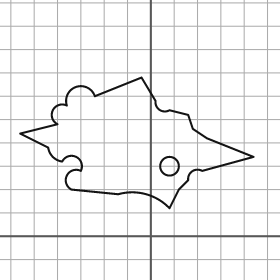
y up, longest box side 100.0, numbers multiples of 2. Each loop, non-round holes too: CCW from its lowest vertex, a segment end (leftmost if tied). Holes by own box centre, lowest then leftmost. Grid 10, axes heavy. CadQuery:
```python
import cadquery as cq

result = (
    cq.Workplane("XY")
    .moveTo(8.0, 12.0)
    .lineTo(12.0, 20.0)
    .lineTo(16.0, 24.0)
    .threePointArc((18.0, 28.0), (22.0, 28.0))
    .lineTo(44.0, 34.0)
    .lineTo(24.0, 42.0)
    .lineTo(18.0, 46.0)
    .lineTo(16.0, 52.0)
    .lineTo(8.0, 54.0)
    .threePointArc((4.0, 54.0), (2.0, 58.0))
    .lineTo(-4.0, 68.0)
    .lineTo(-24.0, 60.0)
    .threePointArc((-32.0, 64.0), (-36.0, 56.0))
    .threePointArc((-42.0, 54.0), (-40.0, 48.0))
    .lineTo(-56.0, 44.0)
    .lineTo(-44.0, 38.0)
    .threePointArc((-42.0, 34.0), (-38.0, 32.0))
    .threePointArc((-32.0, 34.0), (-30.0, 28.0))
    .threePointArc((-36.0, 26.0), (-34.0, 20.0))
    .lineTo(-14.0, 18.0)
    .threePointArc((-2.0, 18.0), (8.0, 12.0))
    .close()
    .moveTo(8.0, 30.0)
    .circle(4.0)
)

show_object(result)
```